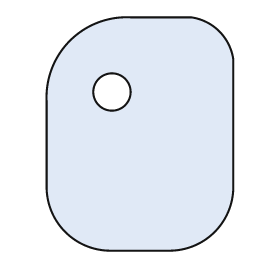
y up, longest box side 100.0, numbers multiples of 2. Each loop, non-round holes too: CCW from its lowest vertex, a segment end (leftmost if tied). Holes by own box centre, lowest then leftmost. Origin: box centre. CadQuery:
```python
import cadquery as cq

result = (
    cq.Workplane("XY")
    .moveTo(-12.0, -50.0)
    .lineTo(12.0, -50.0)
    .threePointArc((32.0, -42.0), (40.0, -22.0))
    .lineTo(40.0, 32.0)
    .threePointArc((34.0, 44.0), (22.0, 50.0))
    .lineTo(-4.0, 50.0)
    .threePointArc((-30.0, 40.0), (-40.0, 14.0))
    .lineTo(-40.0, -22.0)
    .threePointArc((-32.0, -42.0), (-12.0, -50.0))
    .close()
    .moveTo(-12.0, 18.0)
    .circle(8.0)
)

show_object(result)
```